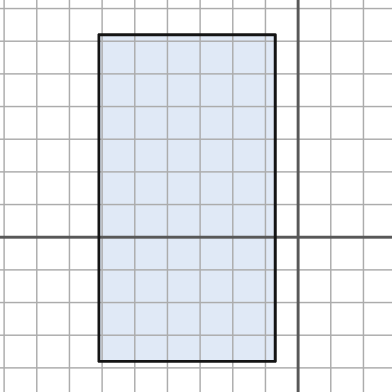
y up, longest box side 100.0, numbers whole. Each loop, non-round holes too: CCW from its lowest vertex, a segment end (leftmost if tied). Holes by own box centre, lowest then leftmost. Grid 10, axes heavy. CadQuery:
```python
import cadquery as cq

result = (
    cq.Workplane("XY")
    .moveTo(-61.0, -38.0)
    .lineTo(-7.0, -38.0)
    .lineTo(-7.0, 62.0)
    .lineTo(-61.0, 62.0)
    .close()
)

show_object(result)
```